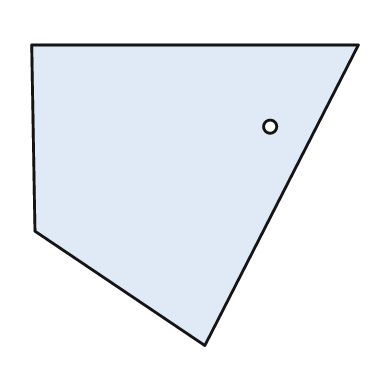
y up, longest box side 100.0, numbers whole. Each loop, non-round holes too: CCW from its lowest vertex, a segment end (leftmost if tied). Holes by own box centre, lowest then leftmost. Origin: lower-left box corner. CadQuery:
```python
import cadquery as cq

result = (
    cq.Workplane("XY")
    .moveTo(53.0, 0.0)
    .lineTo(100.0, 92.0)
    .lineTo(0.0, 92.0)
    .lineTo(1.0, 35.0)
    .close()
    .moveTo(73.0, 67.0)
    .circle(2.0)
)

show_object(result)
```